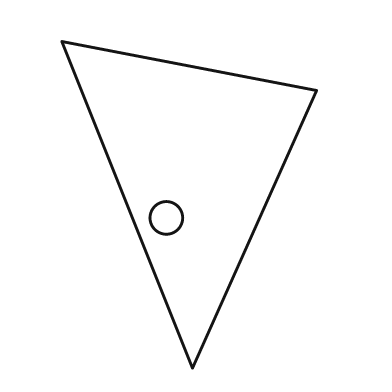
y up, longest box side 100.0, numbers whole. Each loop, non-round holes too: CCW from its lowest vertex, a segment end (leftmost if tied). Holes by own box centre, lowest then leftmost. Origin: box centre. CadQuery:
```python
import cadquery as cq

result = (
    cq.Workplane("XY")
    .moveTo(1.0, -50.0)
    .lineTo(39.0, 35.0)
    .lineTo(-39.0, 50.0)
    .close()
    .moveTo(-7.0, -4.0)
    .circle(5.0)
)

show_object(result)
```